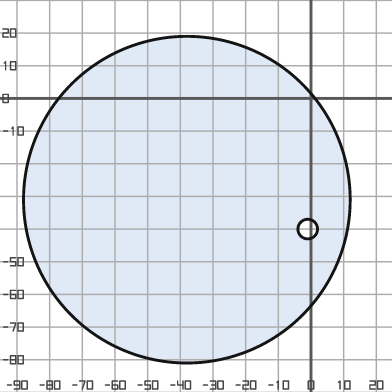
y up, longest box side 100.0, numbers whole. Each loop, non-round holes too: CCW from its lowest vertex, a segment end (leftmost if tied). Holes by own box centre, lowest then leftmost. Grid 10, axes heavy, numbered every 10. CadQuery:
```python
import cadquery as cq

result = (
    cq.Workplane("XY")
    .moveTo(-38.0, -31.0)
    .circle(50.0)
    .moveTo(-1.0, -40.0)
    .circle(3.0)
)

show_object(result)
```